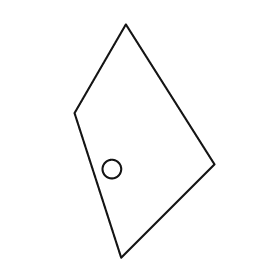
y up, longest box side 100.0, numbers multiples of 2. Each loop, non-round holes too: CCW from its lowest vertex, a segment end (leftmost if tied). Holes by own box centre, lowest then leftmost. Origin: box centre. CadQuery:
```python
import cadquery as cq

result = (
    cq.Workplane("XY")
    .moveTo(-10.0, -50.0)
    .lineTo(30.0, -10.0)
    .lineTo(-8.0, 50.0)
    .lineTo(-30.0, 12.0)
    .close()
    .moveTo(-14.0, -12.0)
    .circle(4.0)
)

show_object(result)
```